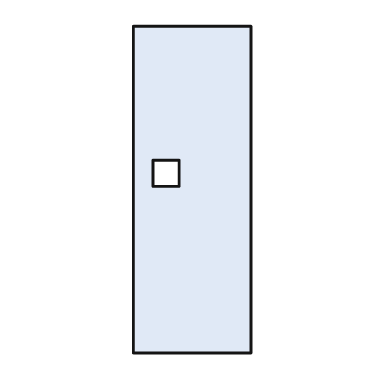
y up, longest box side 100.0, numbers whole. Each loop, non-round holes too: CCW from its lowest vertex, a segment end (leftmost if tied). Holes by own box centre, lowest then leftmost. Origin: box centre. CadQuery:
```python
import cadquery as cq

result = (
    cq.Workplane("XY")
    .moveTo(-18.0, -50.0)
    .lineTo(18.0, -50.0)
    .lineTo(18.0, 50.0)
    .lineTo(-18.0, 50.0)
    .close()
    .moveTo(-12.0, 1.0)
    .lineTo(-4.0, 1.0)
    .lineTo(-4.0, 9.0)
    .lineTo(-12.0, 9.0)
    .close()
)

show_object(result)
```